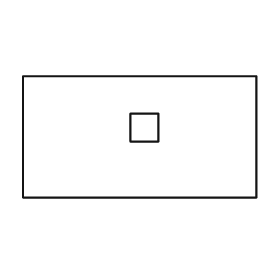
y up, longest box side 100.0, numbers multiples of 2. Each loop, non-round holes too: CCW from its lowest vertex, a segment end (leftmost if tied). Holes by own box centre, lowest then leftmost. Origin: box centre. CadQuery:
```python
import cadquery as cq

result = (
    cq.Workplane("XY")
    .moveTo(-50.0, -26.0)
    .lineTo(50.0, -26.0)
    .lineTo(50.0, 26.0)
    .lineTo(-50.0, 26.0)
    .close()
    .moveTo(-4.0, -2.0)
    .lineTo(8.0, -2.0)
    .lineTo(8.0, 10.0)
    .lineTo(-4.0, 10.0)
    .close()
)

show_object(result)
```